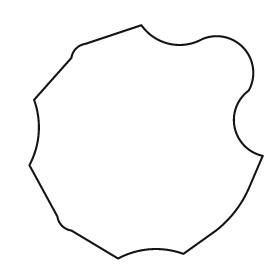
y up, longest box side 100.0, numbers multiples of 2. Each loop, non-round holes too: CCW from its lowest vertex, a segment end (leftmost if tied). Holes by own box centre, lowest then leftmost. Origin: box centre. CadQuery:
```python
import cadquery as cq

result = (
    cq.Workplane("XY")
    .moveTo(-12.0, -50.0)
    .threePointArc((2.0, -46.0), (16.0, -48.0))
    .lineTo(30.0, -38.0)
    .threePointArc((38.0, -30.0), (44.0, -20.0))
    .lineTo(50.0, -6.0)
    .threePointArc((38.0, 6.0), (44.0, 22.0))
    .threePointArc((42.0, 40.0), (24.0, 44.0))
    .threePointArc((10.0, 42.0), (-2.0, 50.0))
    .lineTo(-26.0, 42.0)
    .threePointArc((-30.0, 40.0), (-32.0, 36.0))
    .lineTo(-48.0, 18.0)
    .threePointArc((-46.0, 4.0), (-50.0, -10.0))
    .lineTo(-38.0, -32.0)
    .threePointArc((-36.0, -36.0), (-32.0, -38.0))
    .close()
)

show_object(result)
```